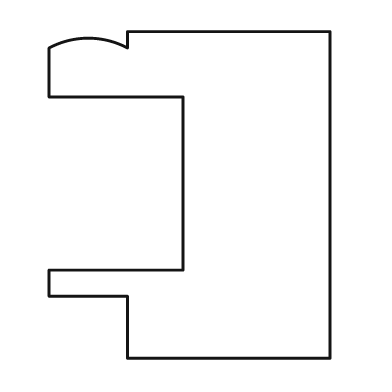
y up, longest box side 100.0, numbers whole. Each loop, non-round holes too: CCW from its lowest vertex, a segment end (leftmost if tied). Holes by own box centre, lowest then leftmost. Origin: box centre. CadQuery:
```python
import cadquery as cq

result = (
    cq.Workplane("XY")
    .moveTo(-19.0, -50.0)
    .lineTo(43.0, -50.0)
    .lineTo(43.0, 50.0)
    .lineTo(-19.0, 50.0)
    .lineTo(-19.0, 45.0)
    .threePointArc((-31.0, 48.0), (-43.0, 45.0))
    .lineTo(-43.0, 30.0)
    .lineTo(-2.0, 30.0)
    .lineTo(-2.0, -23.0)
    .lineTo(-43.0, -23.0)
    .lineTo(-43.0, -31.0)
    .lineTo(-19.0, -31.0)
    .close()
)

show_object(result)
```